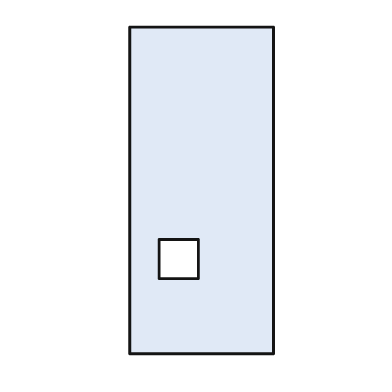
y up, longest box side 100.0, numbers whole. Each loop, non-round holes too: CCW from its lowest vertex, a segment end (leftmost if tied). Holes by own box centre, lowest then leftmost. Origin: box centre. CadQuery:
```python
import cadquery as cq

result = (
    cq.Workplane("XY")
    .moveTo(-22.0, -50.0)
    .lineTo(22.0, -50.0)
    .lineTo(22.0, 50.0)
    .lineTo(-22.0, 50.0)
    .close()
    .moveTo(-13.0, -27.0)
    .lineTo(-1.0, -27.0)
    .lineTo(-1.0, -15.0)
    .lineTo(-13.0, -15.0)
    .close()
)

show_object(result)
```